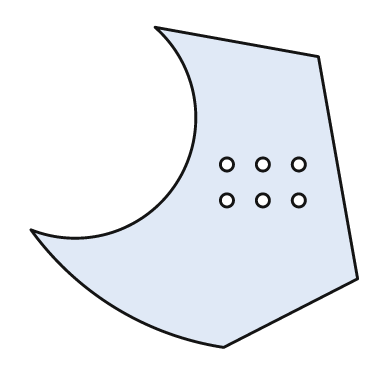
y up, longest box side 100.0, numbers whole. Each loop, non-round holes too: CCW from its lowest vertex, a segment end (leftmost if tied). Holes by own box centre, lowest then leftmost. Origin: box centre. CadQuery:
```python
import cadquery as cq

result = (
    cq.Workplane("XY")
    .moveTo(9.0, -49.0)
    .lineTo(50.0, -28.0)
    .lineTo(38.0, 40.0)
    .lineTo(-12.0, 49.0)
    .threePointArc((-5.0, 2.0), (-50.0, -13.0))
    .threePointArc((-24.0, -37.0), (9.0, -49.0))
    .close()
    .moveTo(10.0, -4.0)
    .circle(2.0)
    .moveTo(21.0, -4.0)
    .circle(2.0)
    .moveTo(32.0, -4.0)
    .circle(2.0)
    .moveTo(10.0, 7.0)
    .circle(2.0)
    .moveTo(21.0, 7.0)
    .circle(2.0)
    .moveTo(32.0, 7.0)
    .circle(2.0)
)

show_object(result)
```